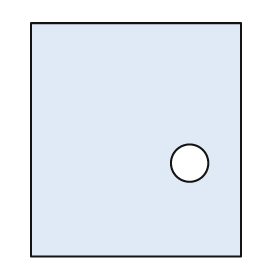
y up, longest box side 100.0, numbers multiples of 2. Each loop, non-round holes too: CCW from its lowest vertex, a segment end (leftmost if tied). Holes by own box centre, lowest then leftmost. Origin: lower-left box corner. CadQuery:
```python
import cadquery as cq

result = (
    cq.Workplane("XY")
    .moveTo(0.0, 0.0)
    .lineTo(90.0, 0.0)
    .lineTo(90.0, 100.0)
    .lineTo(0.0, 100.0)
    .close()
    .moveTo(68.0, 40.0)
    .circle(8.0)
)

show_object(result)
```